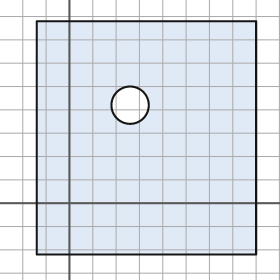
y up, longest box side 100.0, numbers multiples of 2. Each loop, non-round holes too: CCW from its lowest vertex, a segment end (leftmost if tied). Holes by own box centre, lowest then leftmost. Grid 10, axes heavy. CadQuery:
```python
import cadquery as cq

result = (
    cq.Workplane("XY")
    .moveTo(-14.0, -22.0)
    .lineTo(80.0, -22.0)
    .lineTo(80.0, 78.0)
    .lineTo(-14.0, 78.0)
    .close()
    .moveTo(26.0, 42.0)
    .circle(8.0)
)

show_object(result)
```